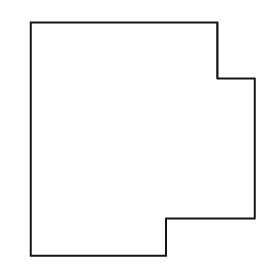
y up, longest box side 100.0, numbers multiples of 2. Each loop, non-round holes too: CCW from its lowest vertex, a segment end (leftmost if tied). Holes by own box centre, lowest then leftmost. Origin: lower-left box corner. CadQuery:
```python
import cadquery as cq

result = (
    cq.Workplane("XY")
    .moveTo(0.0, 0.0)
    .lineTo(58.0, 0.0)
    .lineTo(58.0, 16.0)
    .lineTo(96.0, 16.0)
    .lineTo(96.0, 76.0)
    .lineTo(80.0, 76.0)
    .lineTo(80.0, 100.0)
    .lineTo(0.0, 100.0)
    .close()
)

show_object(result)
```